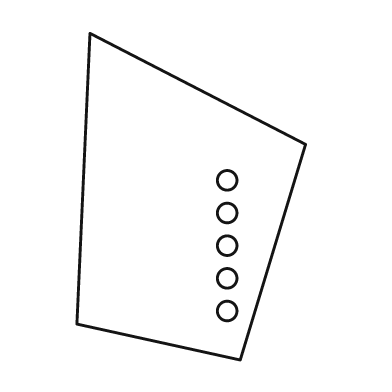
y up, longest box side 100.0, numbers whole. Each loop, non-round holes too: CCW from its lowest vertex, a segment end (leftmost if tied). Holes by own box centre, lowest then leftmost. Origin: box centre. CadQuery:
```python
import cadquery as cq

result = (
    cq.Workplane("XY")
    .moveTo(15.0, -50.0)
    .lineTo(35.0, 16.0)
    .lineTo(-31.0, 50.0)
    .lineTo(-35.0, -39.0)
    .close()
    .moveTo(11.0, -35.0)
    .circle(3.0)
    .moveTo(11.0, -25.0)
    .circle(3.0)
    .moveTo(11.0, -15.0)
    .circle(3.0)
    .moveTo(11.0, -5.0)
    .circle(3.0)
    .moveTo(11.0, 5.0)
    .circle(3.0)
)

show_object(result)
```